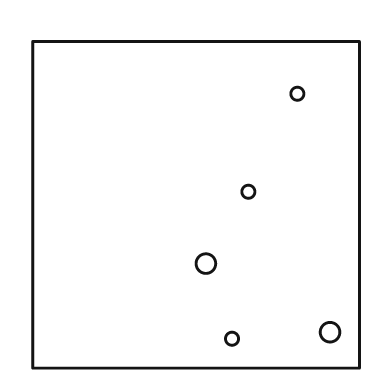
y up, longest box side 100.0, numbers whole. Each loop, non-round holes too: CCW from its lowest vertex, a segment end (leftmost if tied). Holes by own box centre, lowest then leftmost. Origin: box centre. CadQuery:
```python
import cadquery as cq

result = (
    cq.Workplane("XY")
    .moveTo(-50.0, -50.0)
    .lineTo(50.0, -50.0)
    .lineTo(50.0, 50.0)
    .lineTo(-50.0, 50.0)
    .close()
    .moveTo(11.0, -41.0)
    .circle(2.0)
    .moveTo(41.0, -39.0)
    .circle(3.0)
    .moveTo(3.0, -18.0)
    .circle(3.0)
    .moveTo(16.0, 4.0)
    .circle(2.0)
    .moveTo(31.0, 34.0)
    .circle(2.0)
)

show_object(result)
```